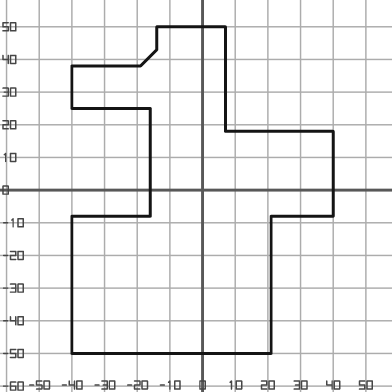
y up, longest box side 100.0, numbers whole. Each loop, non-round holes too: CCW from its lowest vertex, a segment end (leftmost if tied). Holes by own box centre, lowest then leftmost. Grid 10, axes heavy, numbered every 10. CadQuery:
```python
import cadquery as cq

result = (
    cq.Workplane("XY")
    .moveTo(-40.0, -50.0)
    .lineTo(21.0, -50.0)
    .lineTo(21.0, -8.0)
    .lineTo(40.0, -8.0)
    .lineTo(40.0, 18.0)
    .lineTo(7.0, 18.0)
    .lineTo(7.0, 50.0)
    .lineTo(-14.0, 50.0)
    .lineTo(-14.0, 43.0)
    .lineTo(-19.0, 38.0)
    .lineTo(-40.0, 38.0)
    .lineTo(-40.0, 25.0)
    .lineTo(-16.0, 25.0)
    .lineTo(-16.0, -8.0)
    .lineTo(-40.0, -8.0)
    .close()
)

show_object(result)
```